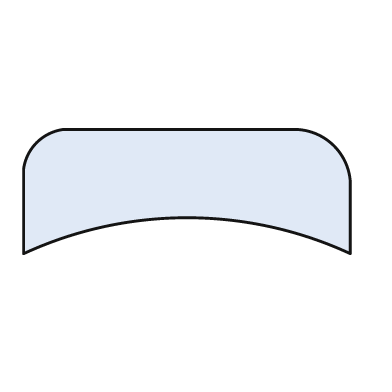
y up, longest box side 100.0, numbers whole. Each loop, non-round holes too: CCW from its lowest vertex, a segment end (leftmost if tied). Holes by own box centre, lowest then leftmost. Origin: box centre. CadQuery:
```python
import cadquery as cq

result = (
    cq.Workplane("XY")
    .moveTo(-50.0, -19.0)
    .threePointArc((0.0, -8.0), (50.0, -19.0))
    .lineTo(50.0, 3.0)
    .threePointArc((45.0, 14.0), (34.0, 19.0))
    .lineTo(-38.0, 19.0)
    .threePointArc((-46.0, 15.0), (-50.0, 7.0))
    .close()
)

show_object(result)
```